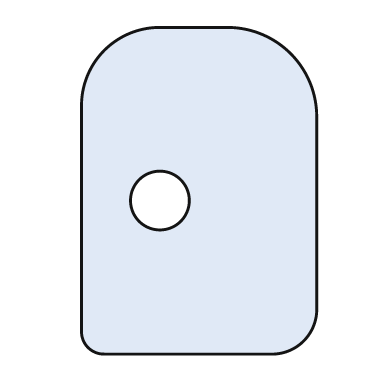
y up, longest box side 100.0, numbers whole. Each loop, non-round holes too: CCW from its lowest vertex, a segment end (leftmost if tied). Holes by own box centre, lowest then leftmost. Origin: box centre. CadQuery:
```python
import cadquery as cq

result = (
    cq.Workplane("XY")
    .moveTo(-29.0, -50.0)
    .lineTo(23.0, -50.0)
    .threePointArc((32.0, -46.0), (36.0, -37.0))
    .lineTo(36.0, 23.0)
    .threePointArc((28.0, 42.0), (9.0, 50.0))
    .lineTo(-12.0, 50.0)
    .threePointArc((-29.0, 43.0), (-36.0, 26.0))
    .lineTo(-36.0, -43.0)
    .threePointArc((-34.0, -48.0), (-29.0, -50.0))
    .close()
    .moveTo(-12.0, -3.0)
    .circle(9.0)
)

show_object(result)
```